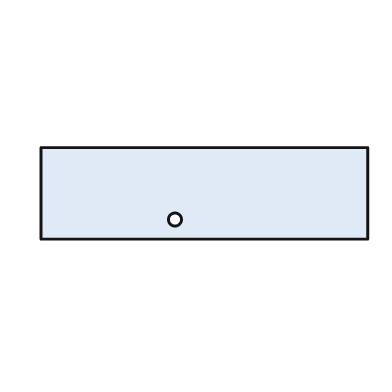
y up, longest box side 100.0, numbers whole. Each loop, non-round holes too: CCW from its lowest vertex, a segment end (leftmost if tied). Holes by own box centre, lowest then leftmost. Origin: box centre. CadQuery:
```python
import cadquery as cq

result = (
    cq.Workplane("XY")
    .moveTo(-50.0, -14.0)
    .lineTo(50.0, -14.0)
    .lineTo(50.0, 14.0)
    .lineTo(-50.0, 14.0)
    .close()
    .moveTo(-9.0, -8.0)
    .circle(2.0)
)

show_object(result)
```